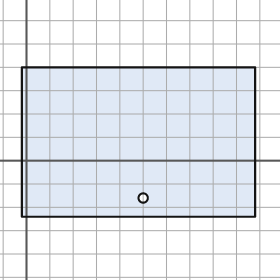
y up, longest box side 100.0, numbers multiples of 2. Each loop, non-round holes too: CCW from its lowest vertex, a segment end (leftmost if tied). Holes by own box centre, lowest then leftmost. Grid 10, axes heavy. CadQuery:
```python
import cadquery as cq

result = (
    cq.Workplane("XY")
    .moveTo(-2.0, -24.0)
    .lineTo(98.0, -24.0)
    .lineTo(98.0, 40.0)
    .lineTo(-2.0, 40.0)
    .close()
    .moveTo(50.0, -16.0)
    .circle(2.0)
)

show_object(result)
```